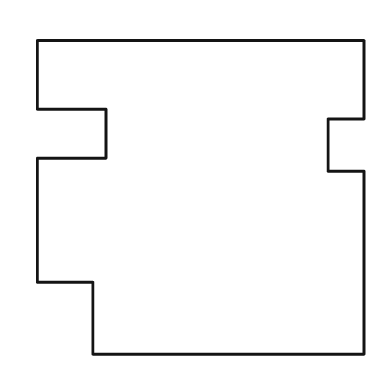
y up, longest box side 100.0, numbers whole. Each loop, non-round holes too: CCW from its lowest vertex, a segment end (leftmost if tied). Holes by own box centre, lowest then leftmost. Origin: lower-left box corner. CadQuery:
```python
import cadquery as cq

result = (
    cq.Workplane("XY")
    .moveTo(17.0, 0.0)
    .lineTo(100.0, 0.0)
    .lineTo(100.0, 56.0)
    .lineTo(89.0, 56.0)
    .lineTo(89.0, 72.0)
    .lineTo(100.0, 72.0)
    .lineTo(100.0, 96.0)
    .lineTo(0.0, 96.0)
    .lineTo(0.0, 75.0)
    .lineTo(21.0, 75.0)
    .lineTo(21.0, 60.0)
    .lineTo(0.0, 60.0)
    .lineTo(0.0, 22.0)
    .lineTo(17.0, 22.0)
    .close()
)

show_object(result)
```